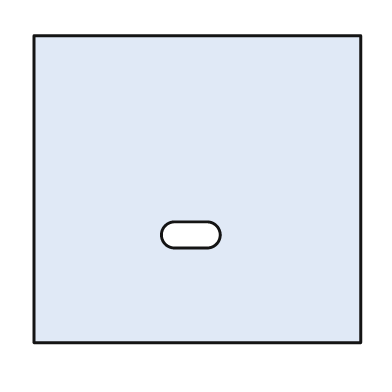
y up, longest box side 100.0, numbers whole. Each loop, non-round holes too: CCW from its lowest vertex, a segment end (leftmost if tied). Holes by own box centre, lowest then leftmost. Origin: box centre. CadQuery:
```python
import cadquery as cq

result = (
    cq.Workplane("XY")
    .moveTo(-50.0, -47.0)
    .lineTo(50.0, -47.0)
    .lineTo(50.0, 47.0)
    .lineTo(-50.0, 47.0)
    .close()
    .moveTo(-7.0, -18.0)
    .lineTo(3.0, -18.0)
    .threePointArc((7.0, -14.0), (3.0, -10.0))
    .lineTo(-7.0, -10.0)
    .threePointArc((-11.0, -14.0), (-7.0, -18.0))
    .close()
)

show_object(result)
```